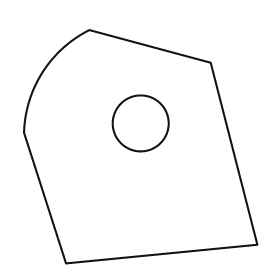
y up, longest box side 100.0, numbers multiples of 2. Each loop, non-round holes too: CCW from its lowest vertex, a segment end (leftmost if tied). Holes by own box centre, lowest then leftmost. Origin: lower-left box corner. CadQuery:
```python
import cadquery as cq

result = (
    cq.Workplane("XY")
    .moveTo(18.0, 0.0)
    .lineTo(100.0, 8.0)
    .lineTo(80.0, 86.0)
    .lineTo(28.0, 100.0)
    .threePointArc((8.0, 82.0), (0.0, 56.0))
    .close()
    .moveTo(50.0, 60.0)
    .circle(12.0)
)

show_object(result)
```